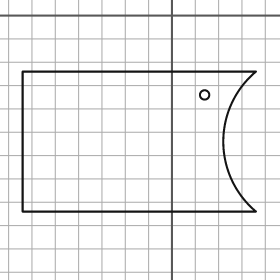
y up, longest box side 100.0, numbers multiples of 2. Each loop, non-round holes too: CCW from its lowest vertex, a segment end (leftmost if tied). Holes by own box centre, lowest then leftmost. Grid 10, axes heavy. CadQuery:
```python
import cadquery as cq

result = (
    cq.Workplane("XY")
    .moveTo(-64.0, -84.0)
    .lineTo(36.0, -84.0)
    .threePointArc((22.0, -54.0), (36.0, -24.0))
    .lineTo(-64.0, -24.0)
    .close()
    .moveTo(14.0, -34.0)
    .circle(2.0)
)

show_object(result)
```